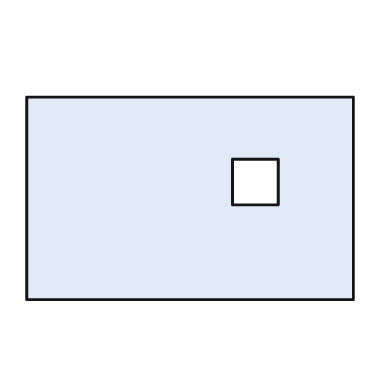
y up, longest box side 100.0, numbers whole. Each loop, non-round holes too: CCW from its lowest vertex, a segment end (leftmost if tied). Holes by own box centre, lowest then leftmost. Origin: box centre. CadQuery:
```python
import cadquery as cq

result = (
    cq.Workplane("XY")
    .moveTo(-50.0, -31.0)
    .lineTo(50.0, -31.0)
    .lineTo(50.0, 31.0)
    .lineTo(-50.0, 31.0)
    .close()
    .moveTo(13.0, -2.0)
    .lineTo(27.0, -2.0)
    .lineTo(27.0, 12.0)
    .lineTo(13.0, 12.0)
    .close()
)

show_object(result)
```